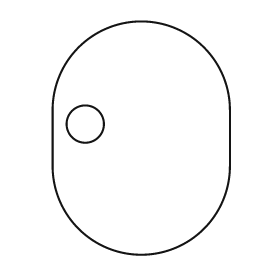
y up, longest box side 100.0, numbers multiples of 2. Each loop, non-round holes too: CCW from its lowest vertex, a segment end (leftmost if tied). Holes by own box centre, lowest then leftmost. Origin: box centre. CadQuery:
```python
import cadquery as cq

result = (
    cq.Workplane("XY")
    .moveTo(-38.0, -12.0)
    .threePointArc((0.0, -50.0), (38.0, -12.0))
    .lineTo(38.0, 12.0)
    .threePointArc((0.0, 50.0), (-38.0, 12.0))
    .close()
    .moveTo(-24.0, 6.0)
    .circle(8.0)
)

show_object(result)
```